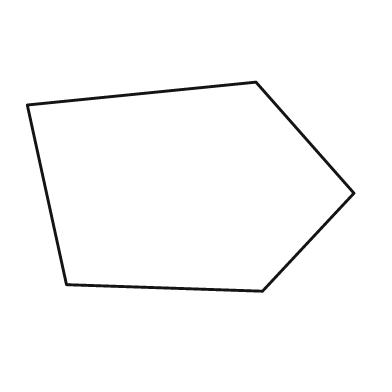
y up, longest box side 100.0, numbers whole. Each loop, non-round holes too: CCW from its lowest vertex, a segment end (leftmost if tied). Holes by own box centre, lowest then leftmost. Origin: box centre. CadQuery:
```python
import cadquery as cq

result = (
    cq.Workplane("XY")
    .moveTo(22.0, -32.0)
    .lineTo(50.0, -2.0)
    .lineTo(20.0, 32.0)
    .lineTo(-50.0, 25.0)
    .lineTo(-38.0, -30.0)
    .close()
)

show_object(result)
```